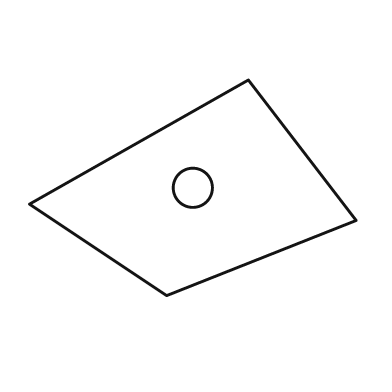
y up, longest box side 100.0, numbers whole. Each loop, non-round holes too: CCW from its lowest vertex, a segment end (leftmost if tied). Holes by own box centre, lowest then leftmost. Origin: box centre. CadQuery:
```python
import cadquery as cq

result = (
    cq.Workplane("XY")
    .moveTo(-8.0, -33.0)
    .lineTo(50.0, -10.0)
    .lineTo(17.0, 33.0)
    .lineTo(-50.0, -5.0)
    .close()
    .moveTo(0.0, 0.0)
    .circle(6.0)
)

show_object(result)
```